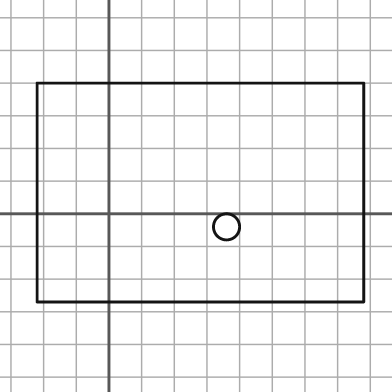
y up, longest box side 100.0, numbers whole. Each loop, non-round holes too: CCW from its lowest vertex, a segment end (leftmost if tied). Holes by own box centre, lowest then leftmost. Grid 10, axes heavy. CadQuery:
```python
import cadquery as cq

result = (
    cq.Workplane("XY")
    .moveTo(-22.0, -27.0)
    .lineTo(78.0, -27.0)
    .lineTo(78.0, 40.0)
    .lineTo(-22.0, 40.0)
    .close()
    .moveTo(36.0, -4.0)
    .circle(4.0)
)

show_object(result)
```